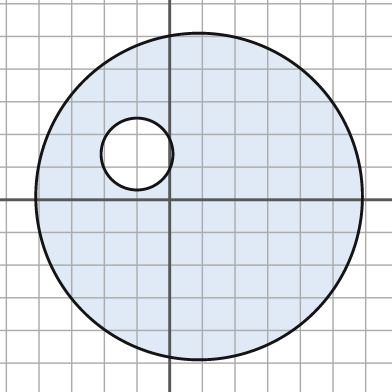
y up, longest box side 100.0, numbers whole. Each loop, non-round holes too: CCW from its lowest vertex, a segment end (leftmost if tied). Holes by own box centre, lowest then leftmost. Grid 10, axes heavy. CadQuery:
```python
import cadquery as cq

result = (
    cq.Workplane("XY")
    .moveTo(9.0, 1.0)
    .circle(50.0)
    .moveTo(-10.0, 14.0)
    .circle(11.0)
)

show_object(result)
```